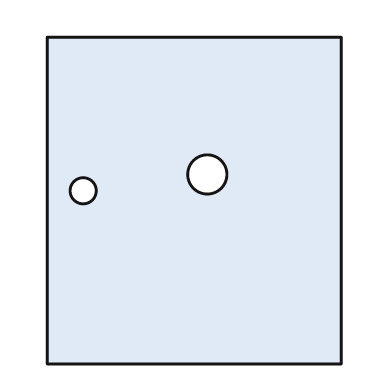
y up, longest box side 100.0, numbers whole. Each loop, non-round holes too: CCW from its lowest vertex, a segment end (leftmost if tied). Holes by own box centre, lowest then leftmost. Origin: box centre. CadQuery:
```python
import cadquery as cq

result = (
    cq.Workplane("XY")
    .moveTo(-45.0, -50.0)
    .lineTo(45.0, -50.0)
    .lineTo(45.0, 50.0)
    .lineTo(-45.0, 50.0)
    .close()
    .moveTo(-34.0, 3.0)
    .circle(4.0)
    .moveTo(4.0, 8.0)
    .circle(6.0)
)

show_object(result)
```